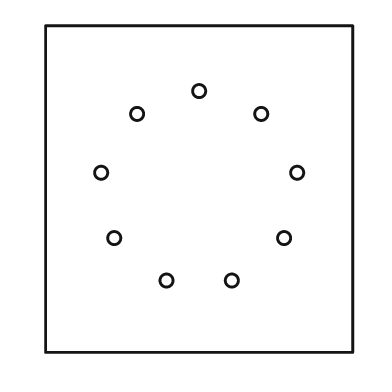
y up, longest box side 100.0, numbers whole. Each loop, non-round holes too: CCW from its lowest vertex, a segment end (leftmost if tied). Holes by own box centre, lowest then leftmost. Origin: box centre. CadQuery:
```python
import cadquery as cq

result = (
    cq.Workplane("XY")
    .moveTo(-47.0, -50.0)
    .lineTo(47.0, -50.0)
    .lineTo(47.0, 50.0)
    .lineTo(-47.0, 50.0)
    .close()
    .moveTo(-10.0, -28.0)
    .circle(2.0)
    .moveTo(10.0, -28.0)
    .circle(2.0)
    .moveTo(-26.0, -15.0)
    .circle(2.0)
    .moveTo(26.0, -15.0)
    .circle(2.0)
    .moveTo(-30.0, 5.0)
    .circle(2.0)
    .moveTo(30.0, 5.0)
    .circle(2.0)
    .moveTo(-19.0, 23.0)
    .circle(2.0)
    .moveTo(19.0, 23.0)
    .circle(2.0)
    .moveTo(0.0, 30.0)
    .circle(2.0)
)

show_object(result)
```